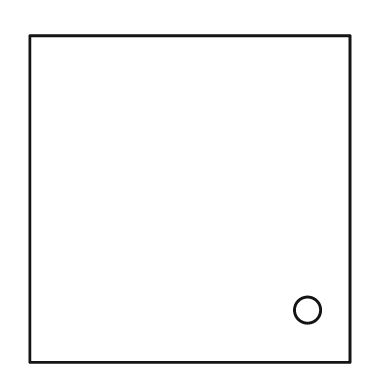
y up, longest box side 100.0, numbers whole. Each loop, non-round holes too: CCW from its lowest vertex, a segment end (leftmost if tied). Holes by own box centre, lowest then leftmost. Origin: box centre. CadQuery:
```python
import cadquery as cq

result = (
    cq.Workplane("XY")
    .moveTo(-49.0, -50.0)
    .lineTo(49.0, -50.0)
    .lineTo(49.0, 50.0)
    .lineTo(-49.0, 50.0)
    .close()
    .moveTo(36.0, -34.0)
    .circle(4.0)
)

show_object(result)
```